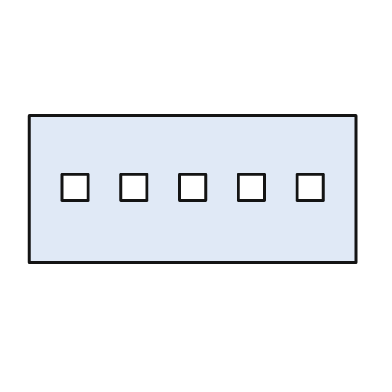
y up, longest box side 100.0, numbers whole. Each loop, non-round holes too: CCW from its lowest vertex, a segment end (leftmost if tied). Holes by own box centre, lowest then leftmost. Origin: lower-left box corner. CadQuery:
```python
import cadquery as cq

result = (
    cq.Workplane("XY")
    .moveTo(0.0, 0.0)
    .lineTo(100.0, 0.0)
    .lineTo(100.0, 45.0)
    .lineTo(0.0, 45.0)
    .close()
    .moveTo(10.0, 19.0)
    .lineTo(18.0, 19.0)
    .lineTo(18.0, 27.0)
    .lineTo(10.0, 27.0)
    .close()
    .moveTo(28.0, 19.0)
    .lineTo(36.0, 19.0)
    .lineTo(36.0, 27.0)
    .lineTo(28.0, 27.0)
    .close()
    .moveTo(46.0, 19.0)
    .lineTo(54.0, 19.0)
    .lineTo(54.0, 27.0)
    .lineTo(46.0, 27.0)
    .close()
    .moveTo(64.0, 19.0)
    .lineTo(72.0, 19.0)
    .lineTo(72.0, 27.0)
    .lineTo(64.0, 27.0)
    .close()
    .moveTo(82.0, 19.0)
    .lineTo(90.0, 19.0)
    .lineTo(90.0, 27.0)
    .lineTo(82.0, 27.0)
    .close()
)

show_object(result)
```